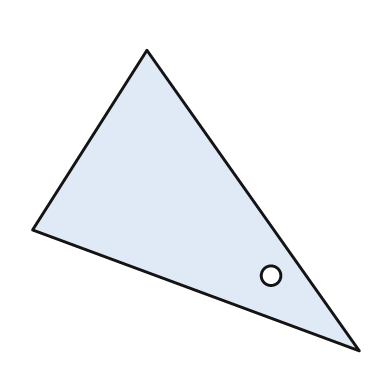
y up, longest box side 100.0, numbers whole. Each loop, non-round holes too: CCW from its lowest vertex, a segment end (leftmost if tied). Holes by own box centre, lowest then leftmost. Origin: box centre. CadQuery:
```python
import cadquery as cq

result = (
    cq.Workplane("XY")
    .moveTo(50.0, -46.0)
    .lineTo(-15.0, 46.0)
    .lineTo(-50.0, -9.0)
    .close()
    .moveTo(23.0, -23.0)
    .circle(3.0)
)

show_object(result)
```